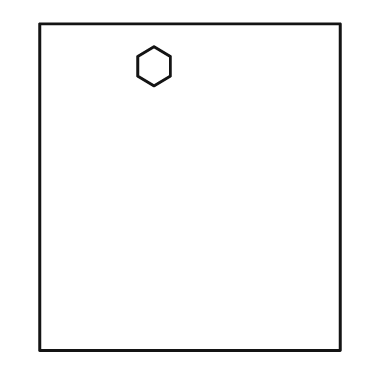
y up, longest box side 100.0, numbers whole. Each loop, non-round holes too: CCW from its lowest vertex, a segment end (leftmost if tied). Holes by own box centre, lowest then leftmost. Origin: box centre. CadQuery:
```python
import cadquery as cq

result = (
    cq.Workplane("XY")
    .moveTo(-46.0, -50.0)
    .lineTo(46.0, -50.0)
    .lineTo(46.0, 50.0)
    .lineTo(-46.0, 50.0)
    .close()
    .moveTo(-11.0, 31.0)
    .lineTo(-6.0, 34.0)
    .lineTo(-6.0, 40.0)
    .lineTo(-11.0, 43.0)
    .lineTo(-16.0, 40.0)
    .lineTo(-16.0, 34.0)
    .close()
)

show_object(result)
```